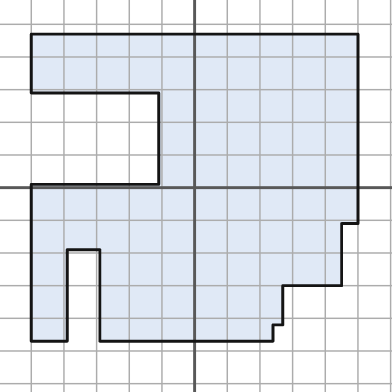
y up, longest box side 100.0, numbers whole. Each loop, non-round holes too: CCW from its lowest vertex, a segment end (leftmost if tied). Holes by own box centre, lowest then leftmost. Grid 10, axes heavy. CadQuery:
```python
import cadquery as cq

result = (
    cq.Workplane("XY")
    .moveTo(-50.0, -47.0)
    .lineTo(-39.0, -47.0)
    .lineTo(-39.0, -19.0)
    .lineTo(-29.0, -19.0)
    .lineTo(-29.0, -47.0)
    .lineTo(24.0, -47.0)
    .lineTo(24.0, -42.0)
    .lineTo(27.0, -42.0)
    .lineTo(27.0, -30.0)
    .lineTo(45.0, -30.0)
    .lineTo(45.0, -11.0)
    .lineTo(50.0, -11.0)
    .lineTo(50.0, 47.0)
    .lineTo(-50.0, 47.0)
    .lineTo(-50.0, 29.0)
    .lineTo(-11.0, 29.0)
    .lineTo(-11.0, 1.0)
    .lineTo(-50.0, 1.0)
    .close()
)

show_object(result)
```